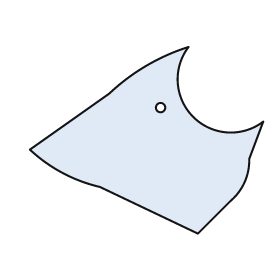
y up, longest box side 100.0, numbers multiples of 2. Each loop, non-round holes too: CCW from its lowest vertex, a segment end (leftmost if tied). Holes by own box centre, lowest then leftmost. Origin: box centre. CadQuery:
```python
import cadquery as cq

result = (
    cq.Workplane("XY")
    .moveTo(22.0, -40.0)
    .lineTo(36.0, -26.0)
    .threePointArc((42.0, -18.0), (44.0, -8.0))
    .lineTo(50.0, 8.0)
    .threePointArc((20.0, 10.0), (18.0, 40.0))
    .threePointArc((0.0, 32.0), (-16.0, 20.0))
    .lineTo(-50.0, -4.0)
    .threePointArc((-36.0, -14.0), (-20.0, -20.0))
    .close()
    .moveTo(6.0, 14.0)
    .circle(2.0)
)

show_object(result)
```